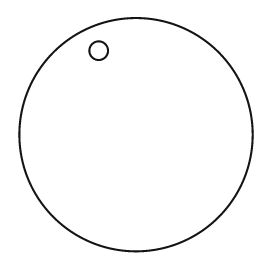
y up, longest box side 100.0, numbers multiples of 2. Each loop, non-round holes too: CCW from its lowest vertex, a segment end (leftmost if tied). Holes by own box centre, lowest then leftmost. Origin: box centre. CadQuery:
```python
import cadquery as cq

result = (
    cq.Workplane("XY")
    .moveTo(0.0, 0.0)
    .circle(50.0)
    .moveTo(-16.0, 36.0)
    .circle(4.0)
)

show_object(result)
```